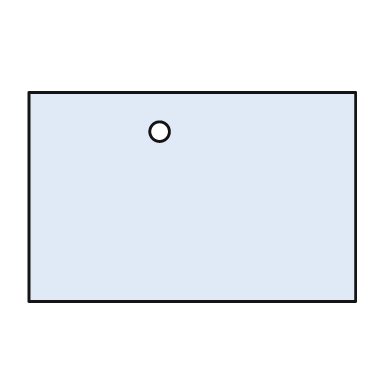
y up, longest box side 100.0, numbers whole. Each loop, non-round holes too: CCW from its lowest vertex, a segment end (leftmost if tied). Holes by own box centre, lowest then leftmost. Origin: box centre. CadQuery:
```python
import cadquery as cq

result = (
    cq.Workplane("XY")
    .moveTo(-50.0, -32.0)
    .lineTo(50.0, -32.0)
    .lineTo(50.0, 32.0)
    .lineTo(-50.0, 32.0)
    .close()
    .moveTo(-10.0, 20.0)
    .circle(3.0)
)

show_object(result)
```